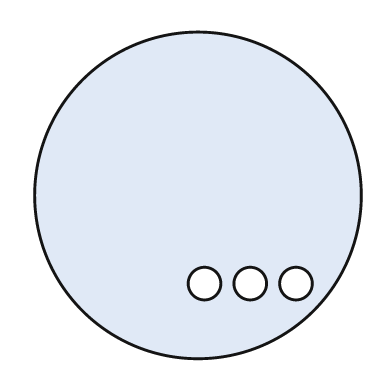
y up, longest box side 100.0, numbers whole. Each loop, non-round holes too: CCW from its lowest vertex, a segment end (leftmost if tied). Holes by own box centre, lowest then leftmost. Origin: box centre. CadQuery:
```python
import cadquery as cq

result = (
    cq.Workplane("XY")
    .moveTo(0.0, 0.0)
    .circle(50.0)
    .moveTo(2.0, -27.0)
    .circle(5.0)
    .moveTo(16.0, -27.0)
    .circle(5.0)
    .moveTo(30.0, -27.0)
    .circle(5.0)
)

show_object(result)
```